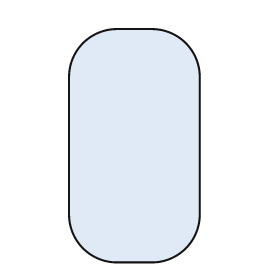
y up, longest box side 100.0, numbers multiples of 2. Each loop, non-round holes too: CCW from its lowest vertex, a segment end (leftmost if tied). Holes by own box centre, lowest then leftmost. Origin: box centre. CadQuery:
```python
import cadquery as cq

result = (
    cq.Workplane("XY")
    .moveTo(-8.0, -50.0)
    .lineTo(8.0, -50.0)
    .threePointArc((22.0, -44.0), (28.0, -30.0))
    .lineTo(28.0, 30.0)
    .threePointArc((22.0, 44.0), (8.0, 50.0))
    .lineTo(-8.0, 50.0)
    .threePointArc((-22.0, 44.0), (-28.0, 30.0))
    .lineTo(-28.0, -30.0)
    .threePointArc((-22.0, -44.0), (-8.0, -50.0))
    .close()
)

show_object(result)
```